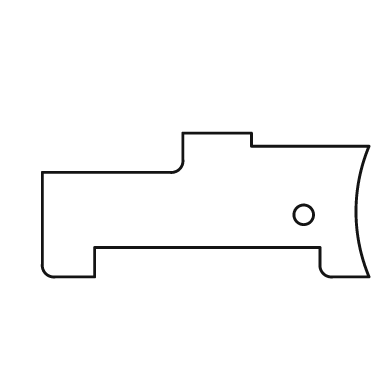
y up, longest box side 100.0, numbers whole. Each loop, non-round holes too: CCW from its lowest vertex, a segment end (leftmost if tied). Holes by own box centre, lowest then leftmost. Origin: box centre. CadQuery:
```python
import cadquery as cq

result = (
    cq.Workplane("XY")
    .moveTo(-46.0, -22.0)
    .lineTo(-34.0, -22.0)
    .lineTo(-34.0, -13.0)
    .lineTo(35.0, -13.0)
    .lineTo(35.0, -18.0)
    .threePointArc((36.0, -21.0), (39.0, -22.0))
    .lineTo(50.0, -22.0)
    .threePointArc((46.0, -2.0), (50.0, 18.0))
    .lineTo(14.0, 18.0)
    .lineTo(14.0, 22.0)
    .lineTo(-7.0, 22.0)
    .lineTo(-7.0, 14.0)
    .threePointArc((-8.0, 11.0), (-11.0, 10.0))
    .lineTo(-50.0, 10.0)
    .lineTo(-50.0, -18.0)
    .threePointArc((-49.0, -21.0), (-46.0, -22.0))
    .close()
    .moveTo(30.0, -3.0)
    .circle(3.0)
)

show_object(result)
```